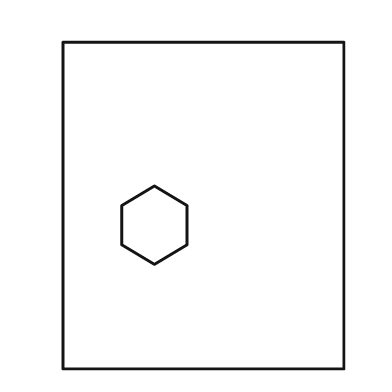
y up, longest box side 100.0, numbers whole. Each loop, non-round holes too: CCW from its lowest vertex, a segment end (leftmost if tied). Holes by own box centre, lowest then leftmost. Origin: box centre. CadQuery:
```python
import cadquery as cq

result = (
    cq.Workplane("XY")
    .moveTo(-43.0, -50.0)
    .lineTo(43.0, -50.0)
    .lineTo(43.0, 50.0)
    .lineTo(-43.0, 50.0)
    .close()
    .moveTo(-15.0, -18.0)
    .lineTo(-5.0, -12.0)
    .lineTo(-5.0, 0.0)
    .lineTo(-15.0, 6.0)
    .lineTo(-25.0, 0.0)
    .lineTo(-25.0, -12.0)
    .close()
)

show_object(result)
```